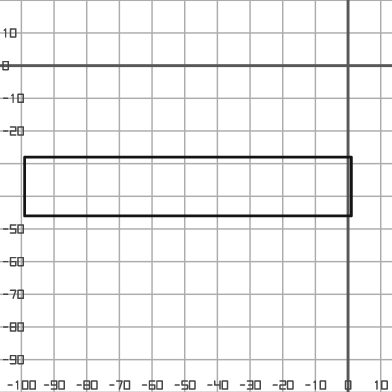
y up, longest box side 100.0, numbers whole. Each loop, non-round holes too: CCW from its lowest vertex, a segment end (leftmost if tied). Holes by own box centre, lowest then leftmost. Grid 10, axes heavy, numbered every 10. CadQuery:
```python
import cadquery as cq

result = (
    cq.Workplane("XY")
    .moveTo(-99.0, -46.0)
    .lineTo(1.0, -46.0)
    .lineTo(1.0, -28.0)
    .lineTo(-99.0, -28.0)
    .close()
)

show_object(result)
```